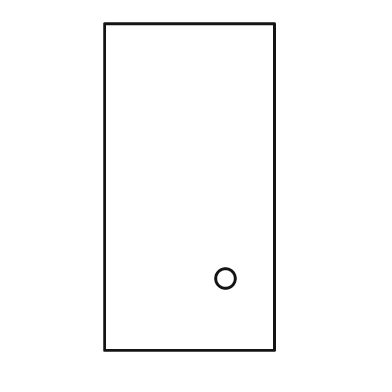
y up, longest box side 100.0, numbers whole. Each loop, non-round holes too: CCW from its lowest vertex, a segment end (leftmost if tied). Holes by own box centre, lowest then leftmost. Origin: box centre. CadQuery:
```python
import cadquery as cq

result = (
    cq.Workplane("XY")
    .moveTo(-26.0, -50.0)
    .lineTo(26.0, -50.0)
    .lineTo(26.0, 50.0)
    .lineTo(-26.0, 50.0)
    .close()
    .moveTo(11.0, -28.0)
    .circle(3.0)
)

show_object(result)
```